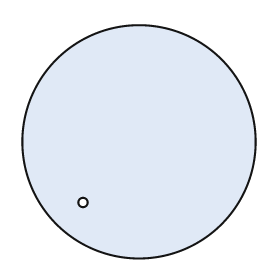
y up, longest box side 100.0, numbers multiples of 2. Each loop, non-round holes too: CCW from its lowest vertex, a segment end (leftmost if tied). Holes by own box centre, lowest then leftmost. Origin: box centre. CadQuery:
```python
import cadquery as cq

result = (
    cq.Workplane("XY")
    .moveTo(0.0, 0.0)
    .circle(50.0)
    .moveTo(-24.0, -26.0)
    .circle(2.0)
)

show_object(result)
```